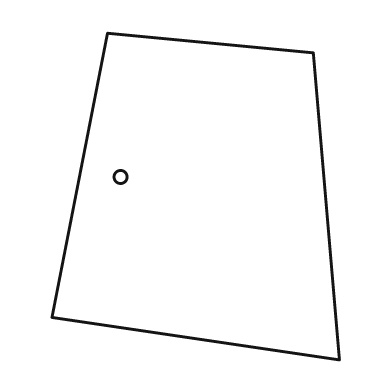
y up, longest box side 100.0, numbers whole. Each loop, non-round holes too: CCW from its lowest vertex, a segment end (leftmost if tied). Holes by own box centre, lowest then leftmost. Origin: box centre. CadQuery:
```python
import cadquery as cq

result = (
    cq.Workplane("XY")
    .moveTo(44.0, -50.0)
    .lineTo(36.0, 44.0)
    .lineTo(-27.0, 50.0)
    .lineTo(-44.0, -37.0)
    .close()
    .moveTo(-23.0, 6.0)
    .circle(2.0)
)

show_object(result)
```